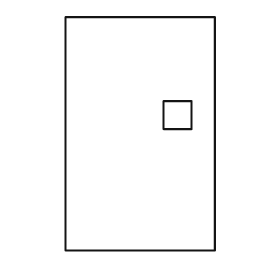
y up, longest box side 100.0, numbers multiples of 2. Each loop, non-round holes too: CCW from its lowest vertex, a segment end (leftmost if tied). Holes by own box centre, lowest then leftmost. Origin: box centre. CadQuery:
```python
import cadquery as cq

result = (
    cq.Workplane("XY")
    .moveTo(-32.0, -50.0)
    .lineTo(32.0, -50.0)
    .lineTo(32.0, 50.0)
    .lineTo(-32.0, 50.0)
    .close()
    .moveTo(10.0, 2.0)
    .lineTo(22.0, 2.0)
    .lineTo(22.0, 14.0)
    .lineTo(10.0, 14.0)
    .close()
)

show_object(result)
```